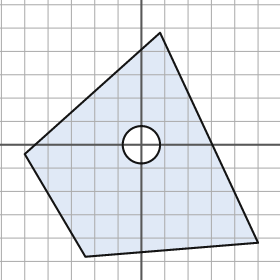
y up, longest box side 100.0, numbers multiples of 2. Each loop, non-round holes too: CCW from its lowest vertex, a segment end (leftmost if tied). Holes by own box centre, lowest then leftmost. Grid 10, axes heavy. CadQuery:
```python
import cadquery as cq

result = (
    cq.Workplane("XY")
    .moveTo(-24.0, -48.0)
    .lineTo(50.0, -42.0)
    .lineTo(8.0, 48.0)
    .lineTo(-50.0, -4.0)
    .close()
    .moveTo(0.0, 0.0)
    .circle(8.0)
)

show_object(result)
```